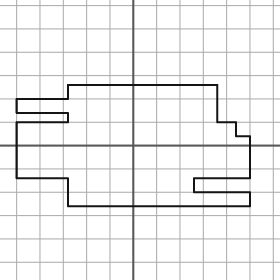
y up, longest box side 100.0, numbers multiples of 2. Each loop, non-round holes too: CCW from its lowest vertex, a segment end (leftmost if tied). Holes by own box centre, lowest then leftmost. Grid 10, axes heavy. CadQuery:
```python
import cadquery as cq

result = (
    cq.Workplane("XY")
    .moveTo(-28.0, -26.0)
    .lineTo(50.0, -26.0)
    .lineTo(50.0, -20.0)
    .lineTo(26.0, -20.0)
    .lineTo(26.0, -14.0)
    .lineTo(50.0, -14.0)
    .lineTo(50.0, 4.0)
    .lineTo(44.0, 4.0)
    .lineTo(44.0, 10.0)
    .lineTo(36.0, 10.0)
    .lineTo(36.0, 26.0)
    .lineTo(-28.0, 26.0)
    .lineTo(-28.0, 20.0)
    .lineTo(-50.0, 20.0)
    .lineTo(-50.0, 14.0)
    .lineTo(-28.0, 14.0)
    .lineTo(-28.0, 10.0)
    .lineTo(-50.0, 10.0)
    .lineTo(-50.0, -14.0)
    .lineTo(-28.0, -14.0)
    .close()
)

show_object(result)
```